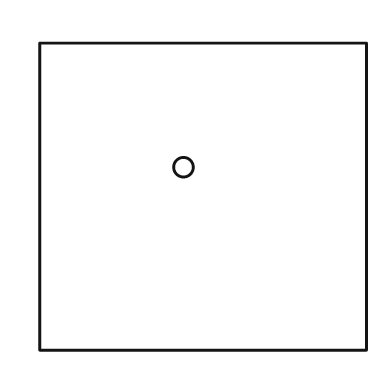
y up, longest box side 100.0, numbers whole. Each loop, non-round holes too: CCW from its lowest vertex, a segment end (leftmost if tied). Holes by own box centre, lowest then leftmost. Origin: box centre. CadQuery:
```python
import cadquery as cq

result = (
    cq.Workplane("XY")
    .moveTo(-50.0, -47.0)
    .lineTo(50.0, -47.0)
    .lineTo(50.0, 47.0)
    .lineTo(-50.0, 47.0)
    .close()
    .moveTo(-6.0, 9.0)
    .circle(3.0)
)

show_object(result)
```